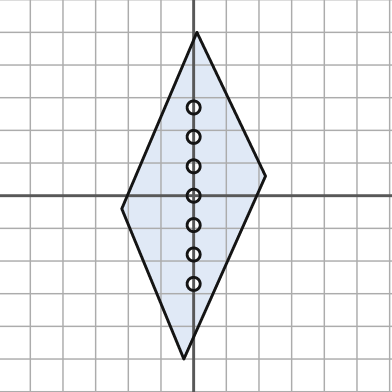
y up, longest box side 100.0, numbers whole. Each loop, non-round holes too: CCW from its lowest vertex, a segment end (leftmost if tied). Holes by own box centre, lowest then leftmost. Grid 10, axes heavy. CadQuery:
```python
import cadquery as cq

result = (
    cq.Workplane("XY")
    .moveTo(-3.0, -50.0)
    .lineTo(22.0, 6.0)
    .lineTo(1.0, 50.0)
    .lineTo(-22.0, -4.0)
    .close()
    .moveTo(0.0, -27.0)
    .circle(2.0)
    .moveTo(0.0, -18.0)
    .circle(2.0)
    .moveTo(0.0, -9.0)
    .circle(2.0)
    .moveTo(0.0, 0.0)
    .circle(2.0)
    .moveTo(0.0, 9.0)
    .circle(2.0)
    .moveTo(0.0, 18.0)
    .circle(2.0)
    .moveTo(0.0, 27.0)
    .circle(2.0)
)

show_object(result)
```